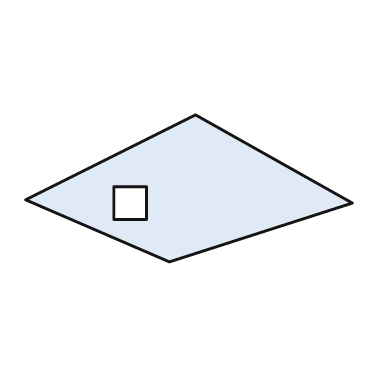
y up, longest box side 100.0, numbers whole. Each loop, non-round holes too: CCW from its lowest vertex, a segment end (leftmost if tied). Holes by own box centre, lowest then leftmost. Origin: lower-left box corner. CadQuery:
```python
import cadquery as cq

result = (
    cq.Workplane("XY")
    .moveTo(44.0, 0.0)
    .lineTo(100.0, 18.0)
    .lineTo(52.0, 45.0)
    .lineTo(0.0, 19.0)
    .close()
    .moveTo(27.0, 13.0)
    .lineTo(37.0, 13.0)
    .lineTo(37.0, 23.0)
    .lineTo(27.0, 23.0)
    .close()
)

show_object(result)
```